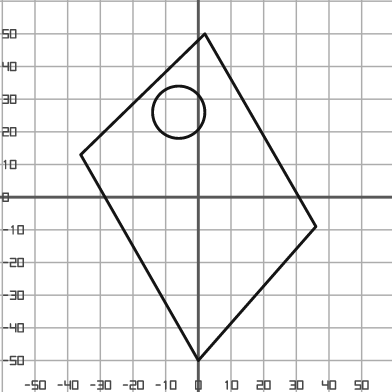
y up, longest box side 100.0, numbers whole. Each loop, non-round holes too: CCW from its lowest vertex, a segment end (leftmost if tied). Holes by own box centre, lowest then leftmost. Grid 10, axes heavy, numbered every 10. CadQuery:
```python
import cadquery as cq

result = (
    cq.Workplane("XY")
    .moveTo(0.0, -50.0)
    .lineTo(36.0, -9.0)
    .lineTo(2.0, 50.0)
    .lineTo(-36.0, 13.0)
    .close()
    .moveTo(-6.0, 26.0)
    .circle(8.0)
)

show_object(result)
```